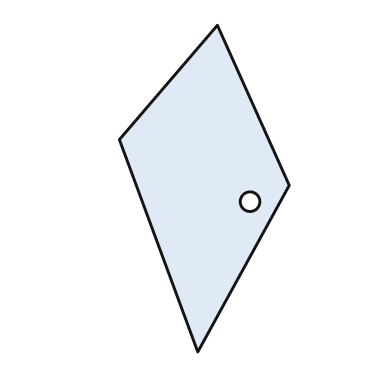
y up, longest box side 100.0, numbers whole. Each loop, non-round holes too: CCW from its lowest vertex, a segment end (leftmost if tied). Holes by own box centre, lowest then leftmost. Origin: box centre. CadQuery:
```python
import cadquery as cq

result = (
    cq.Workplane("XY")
    .moveTo(-2.0, -50.0)
    .lineTo(26.0, 1.0)
    .lineTo(4.0, 50.0)
    .lineTo(-26.0, 15.0)
    .close()
    .moveTo(14.0, -4.0)
    .circle(3.0)
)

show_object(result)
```